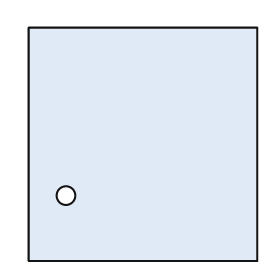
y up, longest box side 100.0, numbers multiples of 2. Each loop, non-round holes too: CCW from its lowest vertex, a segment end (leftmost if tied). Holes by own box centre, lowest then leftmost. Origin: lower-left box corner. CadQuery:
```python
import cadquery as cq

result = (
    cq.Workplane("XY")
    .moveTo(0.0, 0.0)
    .lineTo(98.0, 0.0)
    .lineTo(98.0, 100.0)
    .lineTo(0.0, 100.0)
    .close()
    .moveTo(16.0, 28.0)
    .circle(4.0)
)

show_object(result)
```